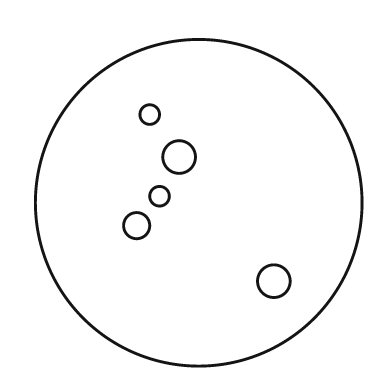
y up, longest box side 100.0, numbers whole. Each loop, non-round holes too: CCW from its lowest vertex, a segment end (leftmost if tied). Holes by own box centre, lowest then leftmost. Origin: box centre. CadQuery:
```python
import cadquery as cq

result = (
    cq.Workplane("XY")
    .moveTo(0.0, 0.0)
    .circle(50.0)
    .moveTo(23.0, -24.0)
    .circle(5.0)
    .moveTo(-19.0, -7.0)
    .circle(4.0)
    .moveTo(-12.0, 2.0)
    .circle(3.0)
    .moveTo(-6.0, 14.0)
    .circle(5.0)
    .moveTo(-15.0, 27.0)
    .circle(3.0)
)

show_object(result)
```